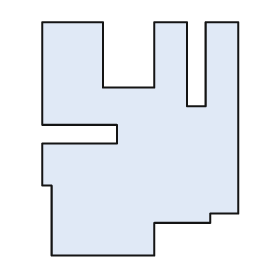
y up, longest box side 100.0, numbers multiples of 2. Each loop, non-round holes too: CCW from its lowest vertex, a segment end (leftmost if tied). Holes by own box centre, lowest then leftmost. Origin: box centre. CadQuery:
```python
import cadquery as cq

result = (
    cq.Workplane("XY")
    .moveTo(-38.0, -50.0)
    .lineTo(6.0, -50.0)
    .lineTo(6.0, -36.0)
    .lineTo(30.0, -36.0)
    .lineTo(30.0, -32.0)
    .lineTo(42.0, -32.0)
    .lineTo(42.0, 50.0)
    .lineTo(28.0, 50.0)
    .lineTo(28.0, 14.0)
    .lineTo(20.0, 14.0)
    .lineTo(20.0, 50.0)
    .lineTo(6.0, 50.0)
    .lineTo(6.0, 22.0)
    .lineTo(-16.0, 22.0)
    .lineTo(-16.0, 50.0)
    .lineTo(-42.0, 50.0)
    .lineTo(-42.0, 6.0)
    .lineTo(-10.0, 6.0)
    .lineTo(-10.0, -2.0)
    .lineTo(-42.0, -2.0)
    .lineTo(-42.0, -20.0)
    .lineTo(-38.0, -20.0)
    .close()
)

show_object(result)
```